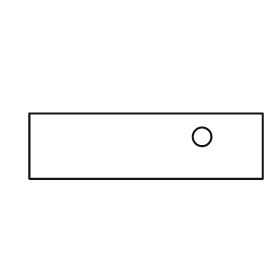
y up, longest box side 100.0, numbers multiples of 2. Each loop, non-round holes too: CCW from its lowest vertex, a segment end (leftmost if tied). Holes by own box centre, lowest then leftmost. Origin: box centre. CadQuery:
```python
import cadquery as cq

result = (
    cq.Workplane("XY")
    .moveTo(-50.0, -14.0)
    .lineTo(50.0, -14.0)
    .lineTo(50.0, 14.0)
    .lineTo(-50.0, 14.0)
    .close()
    .moveTo(24.0, 4.0)
    .circle(4.0)
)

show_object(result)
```